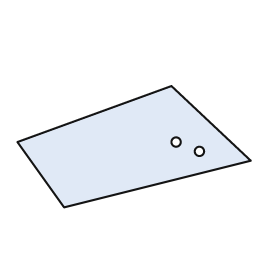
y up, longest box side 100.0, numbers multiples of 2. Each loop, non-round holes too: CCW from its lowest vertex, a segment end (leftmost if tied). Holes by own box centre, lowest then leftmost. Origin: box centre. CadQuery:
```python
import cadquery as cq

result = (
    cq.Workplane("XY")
    .moveTo(-30.0, -26.0)
    .lineTo(50.0, -6.0)
    .lineTo(16.0, 26.0)
    .lineTo(-50.0, 2.0)
    .close()
    .moveTo(28.0, -2.0)
    .circle(2.0)
    .moveTo(18.0, 2.0)
    .circle(2.0)
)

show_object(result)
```